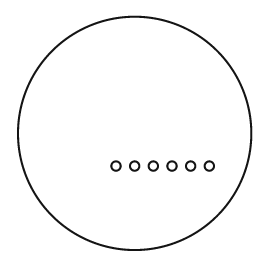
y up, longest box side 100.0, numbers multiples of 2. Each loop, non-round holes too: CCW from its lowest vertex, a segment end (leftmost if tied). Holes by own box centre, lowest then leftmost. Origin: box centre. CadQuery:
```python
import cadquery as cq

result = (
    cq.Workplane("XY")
    .moveTo(0.0, 0.0)
    .circle(50.0)
    .moveTo(-8.0, -14.0)
    .circle(2.0)
    .moveTo(0.0, -14.0)
    .circle(2.0)
    .moveTo(8.0, -14.0)
    .circle(2.0)
    .moveTo(16.0, -14.0)
    .circle(2.0)
    .moveTo(24.0, -14.0)
    .circle(2.0)
    .moveTo(32.0, -14.0)
    .circle(2.0)
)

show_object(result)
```